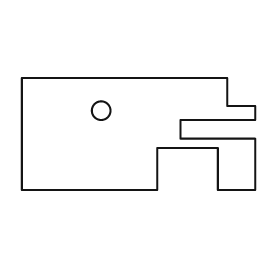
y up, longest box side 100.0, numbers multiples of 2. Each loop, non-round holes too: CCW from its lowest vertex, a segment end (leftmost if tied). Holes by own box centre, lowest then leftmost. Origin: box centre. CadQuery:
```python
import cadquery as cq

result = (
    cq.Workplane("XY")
    .moveTo(-50.0, -24.0)
    .lineTo(8.0, -24.0)
    .lineTo(8.0, -6.0)
    .lineTo(34.0, -6.0)
    .lineTo(34.0, -24.0)
    .lineTo(50.0, -24.0)
    .lineTo(50.0, -2.0)
    .lineTo(18.0, -2.0)
    .lineTo(18.0, 6.0)
    .lineTo(50.0, 6.0)
    .lineTo(50.0, 12.0)
    .lineTo(38.0, 12.0)
    .lineTo(38.0, 24.0)
    .lineTo(-50.0, 24.0)
    .close()
    .moveTo(-16.0, 10.0)
    .circle(4.0)
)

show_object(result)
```